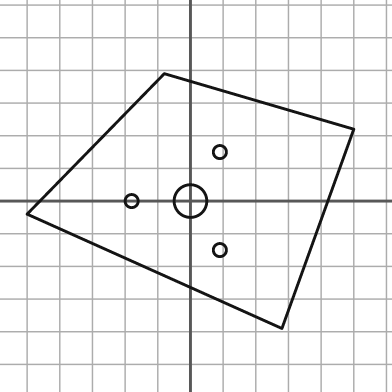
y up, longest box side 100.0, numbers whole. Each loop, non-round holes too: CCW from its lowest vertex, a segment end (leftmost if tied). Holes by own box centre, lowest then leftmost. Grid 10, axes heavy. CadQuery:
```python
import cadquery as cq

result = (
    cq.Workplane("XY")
    .moveTo(28.0, -39.0)
    .lineTo(50.0, 22.0)
    .lineTo(-8.0, 39.0)
    .lineTo(-50.0, -4.0)
    .close()
    .moveTo(9.0, -15.0)
    .circle(2.0)
    .moveTo(-18.0, 0.0)
    .circle(2.0)
    .moveTo(0.0, 0.0)
    .circle(5.0)
    .moveTo(9.0, 15.0)
    .circle(2.0)
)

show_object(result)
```